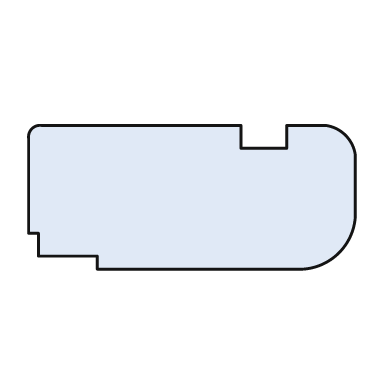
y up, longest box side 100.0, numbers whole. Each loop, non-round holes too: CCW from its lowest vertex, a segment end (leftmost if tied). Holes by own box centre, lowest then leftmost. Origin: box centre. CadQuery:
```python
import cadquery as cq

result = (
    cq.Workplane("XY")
    .moveTo(-29.0, -22.0)
    .lineTo(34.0, -22.0)
    .threePointArc((45.0, -17.0), (50.0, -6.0))
    .lineTo(50.0, 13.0)
    .threePointArc((47.0, 19.0), (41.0, 22.0))
    .lineTo(29.0, 22.0)
    .lineTo(29.0, 15.0)
    .lineTo(15.0, 15.0)
    .lineTo(15.0, 22.0)
    .lineTo(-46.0, 22.0)
    .threePointArc((-49.0, 21.0), (-50.0, 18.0))
    .lineTo(-50.0, -11.0)
    .lineTo(-47.0, -11.0)
    .lineTo(-47.0, -18.0)
    .lineTo(-29.0, -18.0)
    .close()
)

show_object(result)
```